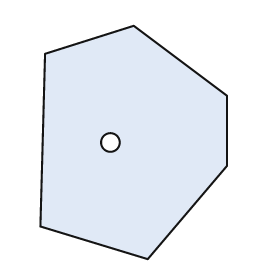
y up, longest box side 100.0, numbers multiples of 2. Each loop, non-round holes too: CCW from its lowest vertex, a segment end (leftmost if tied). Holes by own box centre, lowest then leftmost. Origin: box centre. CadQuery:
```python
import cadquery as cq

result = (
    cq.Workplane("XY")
    .moveTo(6.0, -50.0)
    .lineTo(40.0, -10.0)
    .lineTo(40.0, 20.0)
    .lineTo(0.0, 50.0)
    .lineTo(-38.0, 38.0)
    .lineTo(-40.0, -36.0)
    .close()
    .moveTo(-10.0, 0.0)
    .circle(4.0)
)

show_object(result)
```